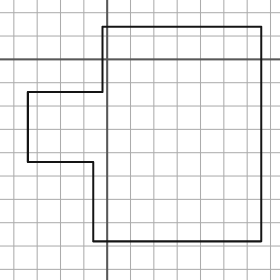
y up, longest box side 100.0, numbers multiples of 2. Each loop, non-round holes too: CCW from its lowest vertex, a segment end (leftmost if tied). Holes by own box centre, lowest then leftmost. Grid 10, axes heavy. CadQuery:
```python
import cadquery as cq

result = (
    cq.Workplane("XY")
    .moveTo(-6.0, -78.0)
    .lineTo(66.0, -78.0)
    .lineTo(66.0, 14.0)
    .lineTo(-2.0, 14.0)
    .lineTo(-2.0, -14.0)
    .lineTo(-34.0, -14.0)
    .lineTo(-34.0, -44.0)
    .lineTo(-6.0, -44.0)
    .close()
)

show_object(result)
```